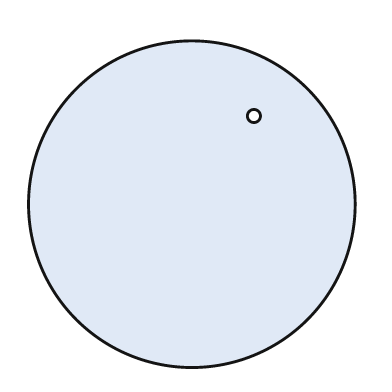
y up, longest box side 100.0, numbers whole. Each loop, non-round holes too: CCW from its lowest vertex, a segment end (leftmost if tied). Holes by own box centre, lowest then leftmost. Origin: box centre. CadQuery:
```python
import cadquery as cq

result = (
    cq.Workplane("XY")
    .moveTo(0.0, 0.0)
    .circle(50.0)
    .moveTo(19.0, 27.0)
    .circle(2.0)
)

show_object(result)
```